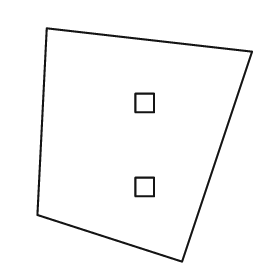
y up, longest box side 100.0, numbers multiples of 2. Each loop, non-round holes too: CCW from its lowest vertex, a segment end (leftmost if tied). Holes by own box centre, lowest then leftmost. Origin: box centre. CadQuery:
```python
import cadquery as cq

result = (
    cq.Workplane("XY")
    .moveTo(16.0, -50.0)
    .lineTo(46.0, 40.0)
    .lineTo(-42.0, 50.0)
    .lineTo(-46.0, -30.0)
    .close()
    .moveTo(-4.0, -22.0)
    .lineTo(4.0, -22.0)
    .lineTo(4.0, -14.0)
    .lineTo(-4.0, -14.0)
    .close()
    .moveTo(-4.0, 14.0)
    .lineTo(4.0, 14.0)
    .lineTo(4.0, 22.0)
    .lineTo(-4.0, 22.0)
    .close()
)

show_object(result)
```